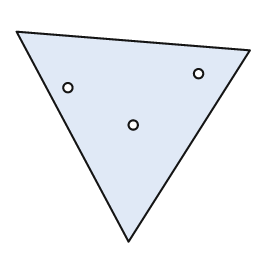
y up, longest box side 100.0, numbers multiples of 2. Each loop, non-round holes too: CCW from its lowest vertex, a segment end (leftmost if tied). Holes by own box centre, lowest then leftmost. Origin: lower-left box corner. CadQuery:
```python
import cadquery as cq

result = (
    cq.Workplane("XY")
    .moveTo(48.0, 0.0)
    .lineTo(100.0, 82.0)
    .lineTo(0.0, 90.0)
    .close()
    .moveTo(50.0, 50.0)
    .circle(2.0)
    .moveTo(22.0, 66.0)
    .circle(2.0)
    .moveTo(78.0, 72.0)
    .circle(2.0)
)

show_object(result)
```